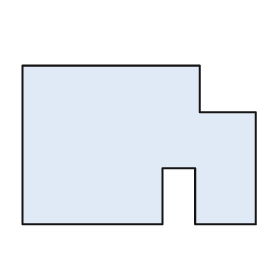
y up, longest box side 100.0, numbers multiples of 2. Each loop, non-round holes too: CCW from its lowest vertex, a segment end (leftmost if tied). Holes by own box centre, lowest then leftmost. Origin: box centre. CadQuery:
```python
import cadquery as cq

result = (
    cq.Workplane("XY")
    .moveTo(-50.0, -34.0)
    .lineTo(10.0, -34.0)
    .lineTo(10.0, -10.0)
    .lineTo(24.0, -10.0)
    .lineTo(24.0, -34.0)
    .lineTo(50.0, -34.0)
    .lineTo(50.0, 14.0)
    .lineTo(26.0, 14.0)
    .lineTo(26.0, 34.0)
    .lineTo(-50.0, 34.0)
    .close()
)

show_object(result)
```